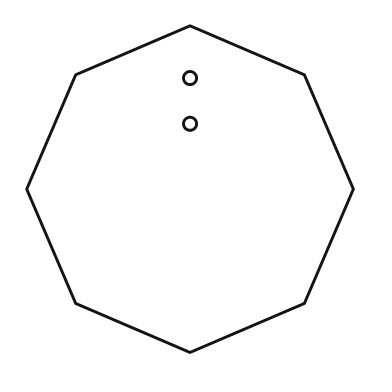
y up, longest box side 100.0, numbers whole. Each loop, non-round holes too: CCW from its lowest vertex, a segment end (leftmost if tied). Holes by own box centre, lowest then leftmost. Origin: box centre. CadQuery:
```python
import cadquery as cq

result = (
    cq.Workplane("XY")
    .moveTo(0.0, -50.0)
    .lineTo(35.0, -35.0)
    .lineTo(50.0, 0.0)
    .lineTo(35.0, 35.0)
    .lineTo(0.0, 50.0)
    .lineTo(-35.0, 35.0)
    .lineTo(-50.0, 0.0)
    .lineTo(-35.0, -35.0)
    .close()
    .moveTo(0.0, 20.0)
    .circle(2.0)
    .moveTo(0.0, 34.0)
    .circle(2.0)
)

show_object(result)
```